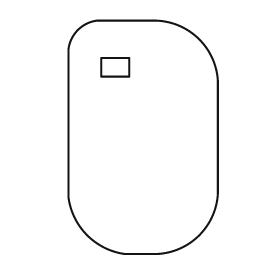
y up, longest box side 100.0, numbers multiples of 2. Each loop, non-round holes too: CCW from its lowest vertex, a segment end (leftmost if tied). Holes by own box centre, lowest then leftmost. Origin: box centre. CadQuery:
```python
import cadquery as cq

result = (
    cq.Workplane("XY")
    .moveTo(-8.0, -50.0)
    .lineTo(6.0, -50.0)
    .threePointArc((24.0, -42.0), (32.0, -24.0))
    .lineTo(32.0, 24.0)
    .threePointArc((24.0, 42.0), (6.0, 50.0))
    .lineTo(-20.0, 50.0)
    .threePointArc((-28.0, 46.0), (-32.0, 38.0))
    .lineTo(-32.0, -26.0)
    .threePointArc((-24.0, -42.0), (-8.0, -50.0))
    .close()
    .moveTo(-18.0, 26.0)
    .lineTo(-6.0, 26.0)
    .lineTo(-6.0, 34.0)
    .lineTo(-18.0, 34.0)
    .close()
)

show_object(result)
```